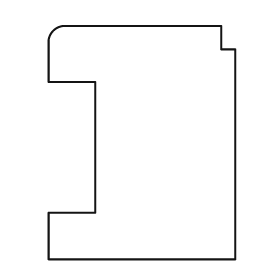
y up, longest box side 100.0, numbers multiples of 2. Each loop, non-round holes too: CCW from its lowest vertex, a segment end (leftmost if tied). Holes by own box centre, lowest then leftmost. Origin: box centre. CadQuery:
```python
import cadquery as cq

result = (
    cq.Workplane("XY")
    .moveTo(-40.0, -50.0)
    .lineTo(40.0, -50.0)
    .lineTo(40.0, 40.0)
    .lineTo(34.0, 40.0)
    .lineTo(34.0, 50.0)
    .lineTo(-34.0, 50.0)
    .threePointArc((-38.0, 48.0), (-40.0, 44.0))
    .lineTo(-40.0, 26.0)
    .lineTo(-20.0, 26.0)
    .lineTo(-20.0, -30.0)
    .lineTo(-40.0, -30.0)
    .close()
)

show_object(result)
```